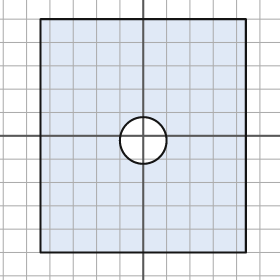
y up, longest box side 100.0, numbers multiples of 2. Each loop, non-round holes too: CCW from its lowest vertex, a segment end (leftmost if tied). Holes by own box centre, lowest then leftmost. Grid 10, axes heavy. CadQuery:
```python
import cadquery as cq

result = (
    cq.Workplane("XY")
    .moveTo(-44.0, -50.0)
    .lineTo(44.0, -50.0)
    .lineTo(44.0, 50.0)
    .lineTo(-44.0, 50.0)
    .close()
    .moveTo(0.0, -2.0)
    .circle(10.0)
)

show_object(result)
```